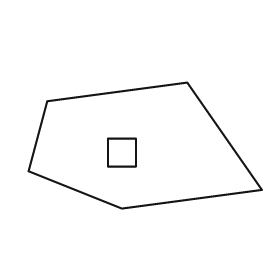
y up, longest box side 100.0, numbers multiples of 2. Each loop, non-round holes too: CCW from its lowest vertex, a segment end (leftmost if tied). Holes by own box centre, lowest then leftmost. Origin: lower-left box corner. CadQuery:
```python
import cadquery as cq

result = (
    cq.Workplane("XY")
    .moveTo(40.0, 0.0)
    .lineTo(100.0, 8.0)
    .lineTo(68.0, 54.0)
    .lineTo(8.0, 46.0)
    .lineTo(0.0, 16.0)
    .close()
    .moveTo(34.0, 18.0)
    .lineTo(46.0, 18.0)
    .lineTo(46.0, 30.0)
    .lineTo(34.0, 30.0)
    .close()
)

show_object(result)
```